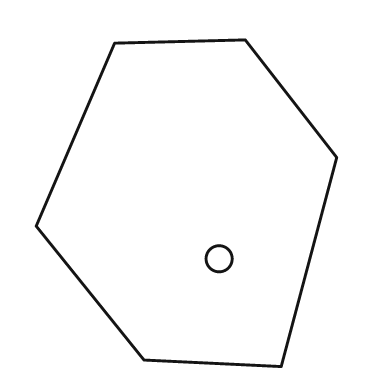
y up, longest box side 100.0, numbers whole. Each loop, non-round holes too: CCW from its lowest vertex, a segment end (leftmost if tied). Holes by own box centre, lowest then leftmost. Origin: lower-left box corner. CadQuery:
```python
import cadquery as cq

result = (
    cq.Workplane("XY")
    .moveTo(75.0, 0.0)
    .lineTo(92.0, 64.0)
    .lineTo(64.0, 100.0)
    .lineTo(24.0, 99.0)
    .lineTo(0.0, 43.0)
    .lineTo(33.0, 2.0)
    .close()
    .moveTo(56.0, 33.0)
    .circle(4.0)
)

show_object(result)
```